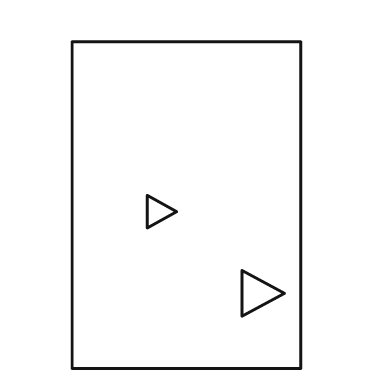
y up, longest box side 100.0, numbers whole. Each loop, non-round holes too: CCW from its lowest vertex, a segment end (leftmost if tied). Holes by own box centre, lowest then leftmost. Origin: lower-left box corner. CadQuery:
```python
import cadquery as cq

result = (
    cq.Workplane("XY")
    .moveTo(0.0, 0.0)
    .lineTo(70.0, 0.0)
    .lineTo(70.0, 100.0)
    .lineTo(0.0, 100.0)
    .close()
    .moveTo(52.0, 16.0)
    .lineTo(65.0, 23.0)
    .lineTo(52.0, 30.0)
    .close()
    .moveTo(23.0, 43.0)
    .lineTo(32.0, 48.0)
    .lineTo(23.0, 53.0)
    .close()
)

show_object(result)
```